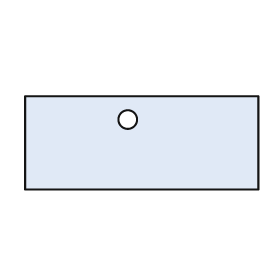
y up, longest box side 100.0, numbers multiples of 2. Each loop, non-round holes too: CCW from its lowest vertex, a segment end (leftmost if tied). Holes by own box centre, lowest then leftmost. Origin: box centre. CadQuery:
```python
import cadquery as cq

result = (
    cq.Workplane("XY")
    .moveTo(-50.0, -20.0)
    .lineTo(50.0, -20.0)
    .lineTo(50.0, 20.0)
    .lineTo(-50.0, 20.0)
    .close()
    .moveTo(-6.0, 10.0)
    .circle(4.0)
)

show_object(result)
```